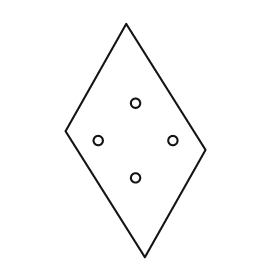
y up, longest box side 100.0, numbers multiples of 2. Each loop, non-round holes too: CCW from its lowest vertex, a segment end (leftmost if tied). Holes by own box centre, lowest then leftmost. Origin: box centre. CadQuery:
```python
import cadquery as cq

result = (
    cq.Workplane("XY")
    .moveTo(4.0, -50.0)
    .lineTo(30.0, -4.0)
    .lineTo(-4.0, 50.0)
    .lineTo(-30.0, 4.0)
    .close()
    .moveTo(0.0, -16.0)
    .circle(2.0)
    .moveTo(-16.0, 0.0)
    .circle(2.0)
    .moveTo(16.0, 0.0)
    .circle(2.0)
    .moveTo(0.0, 16.0)
    .circle(2.0)
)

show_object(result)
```